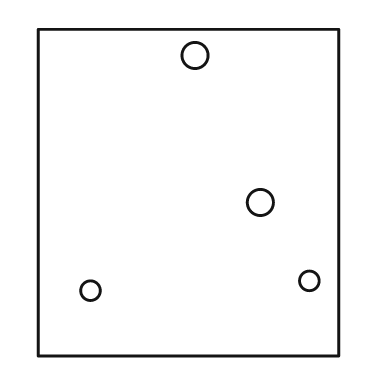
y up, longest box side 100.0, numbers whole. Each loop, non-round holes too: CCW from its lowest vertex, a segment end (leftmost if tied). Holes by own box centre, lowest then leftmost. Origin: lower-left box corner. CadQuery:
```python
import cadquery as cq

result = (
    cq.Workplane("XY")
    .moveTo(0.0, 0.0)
    .lineTo(92.0, 0.0)
    .lineTo(92.0, 100.0)
    .lineTo(0.0, 100.0)
    .close()
    .moveTo(16.0, 20.0)
    .circle(3.0)
    .moveTo(83.0, 23.0)
    .circle(3.0)
    .moveTo(68.0, 47.0)
    .circle(4.0)
    .moveTo(48.0, 92.0)
    .circle(4.0)
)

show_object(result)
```